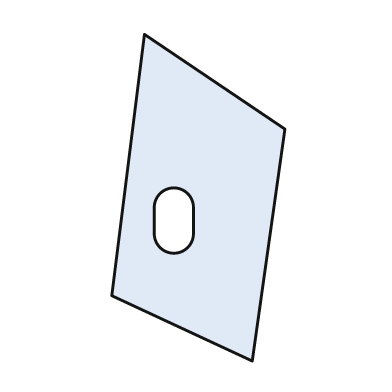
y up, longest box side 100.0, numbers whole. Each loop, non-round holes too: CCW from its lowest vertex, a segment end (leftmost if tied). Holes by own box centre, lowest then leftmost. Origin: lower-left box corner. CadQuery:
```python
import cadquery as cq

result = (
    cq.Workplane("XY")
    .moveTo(43.0, 0.0)
    .lineTo(53.0, 71.0)
    .lineTo(10.0, 100.0)
    .lineTo(0.0, 20.0)
    .close()
    .moveTo(13.0, 39.0)
    .threePointArc((19.0, 33.0), (25.0, 39.0))
    .lineTo(25.0, 47.0)
    .threePointArc((19.0, 53.0), (13.0, 47.0))
    .close()
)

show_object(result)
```